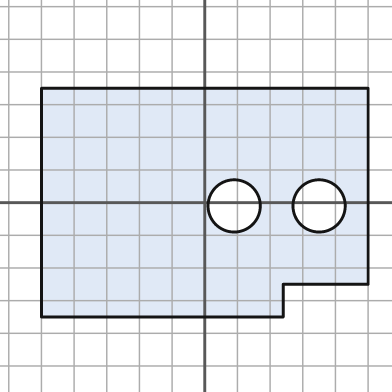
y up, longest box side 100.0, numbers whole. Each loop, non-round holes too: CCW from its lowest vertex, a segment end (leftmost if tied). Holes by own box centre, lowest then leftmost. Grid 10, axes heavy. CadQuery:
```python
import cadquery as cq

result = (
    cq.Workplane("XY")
    .moveTo(-50.0, -35.0)
    .lineTo(24.0, -35.0)
    .lineTo(24.0, -25.0)
    .lineTo(50.0, -25.0)
    .lineTo(50.0, 35.0)
    .lineTo(-50.0, 35.0)
    .close()
    .moveTo(9.0, -1.0)
    .circle(8.0)
    .moveTo(35.0, -1.0)
    .circle(8.0)
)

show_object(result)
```